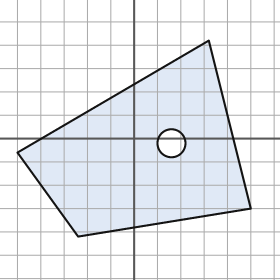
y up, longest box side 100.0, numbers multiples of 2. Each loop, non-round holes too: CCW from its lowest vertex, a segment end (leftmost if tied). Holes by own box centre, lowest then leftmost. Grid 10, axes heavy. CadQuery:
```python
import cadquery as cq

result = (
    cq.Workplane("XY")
    .moveTo(-24.0, -42.0)
    .lineTo(50.0, -30.0)
    .lineTo(32.0, 42.0)
    .lineTo(-50.0, -6.0)
    .close()
    .moveTo(16.0, -2.0)
    .circle(6.0)
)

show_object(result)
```